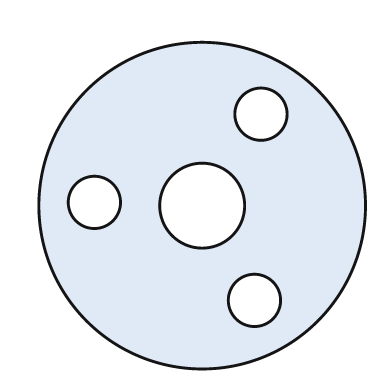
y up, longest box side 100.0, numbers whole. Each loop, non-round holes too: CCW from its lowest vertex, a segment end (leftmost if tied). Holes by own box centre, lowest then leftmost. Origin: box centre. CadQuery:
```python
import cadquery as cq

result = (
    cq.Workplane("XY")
    .moveTo(0.0, 0.0)
    .circle(50.0)
    .moveTo(16.0, -29.0)
    .circle(8.0)
    .moveTo(0.0, 0.0)
    .circle(13.0)
    .moveTo(-33.0, 1.0)
    .circle(8.0)
    .moveTo(18.0, 28.0)
    .circle(8.0)
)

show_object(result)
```